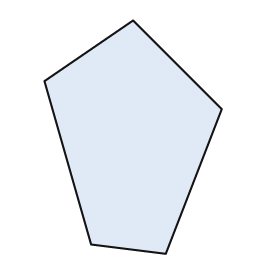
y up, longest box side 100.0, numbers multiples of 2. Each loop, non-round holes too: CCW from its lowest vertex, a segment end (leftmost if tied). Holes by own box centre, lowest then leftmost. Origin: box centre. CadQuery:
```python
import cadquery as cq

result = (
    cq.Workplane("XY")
    .moveTo(14.0, -50.0)
    .lineTo(38.0, 12.0)
    .lineTo(0.0, 50.0)
    .lineTo(-38.0, 24.0)
    .lineTo(-18.0, -46.0)
    .close()
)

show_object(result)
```